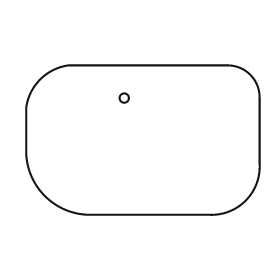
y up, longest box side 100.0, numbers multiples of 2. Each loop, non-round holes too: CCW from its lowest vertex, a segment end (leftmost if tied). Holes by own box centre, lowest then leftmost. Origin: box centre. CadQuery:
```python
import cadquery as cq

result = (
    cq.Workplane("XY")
    .moveTo(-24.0, -32.0)
    .lineTo(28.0, -32.0)
    .threePointArc((44.0, -26.0), (50.0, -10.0))
    .lineTo(50.0, 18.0)
    .threePointArc((46.0, 28.0), (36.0, 32.0))
    .lineTo(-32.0, 32.0)
    .threePointArc((-44.0, 26.0), (-50.0, 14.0))
    .lineTo(-50.0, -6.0)
    .threePointArc((-42.0, -24.0), (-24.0, -32.0))
    .close()
    .moveTo(-8.0, 18.0)
    .circle(2.0)
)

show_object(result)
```